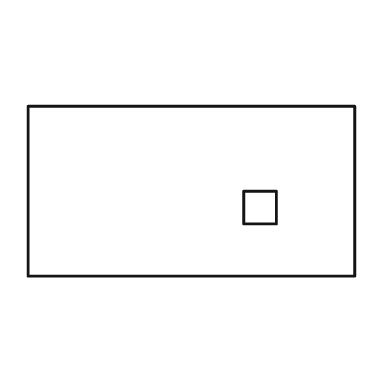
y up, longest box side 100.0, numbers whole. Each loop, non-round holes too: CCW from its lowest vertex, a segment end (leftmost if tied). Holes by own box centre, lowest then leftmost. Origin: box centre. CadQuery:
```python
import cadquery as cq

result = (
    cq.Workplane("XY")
    .moveTo(-50.0, -26.0)
    .lineTo(50.0, -26.0)
    .lineTo(50.0, 26.0)
    .lineTo(-50.0, 26.0)
    .close()
    .moveTo(16.0, -10.0)
    .lineTo(26.0, -10.0)
    .lineTo(26.0, 0.0)
    .lineTo(16.0, 0.0)
    .close()
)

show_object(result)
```